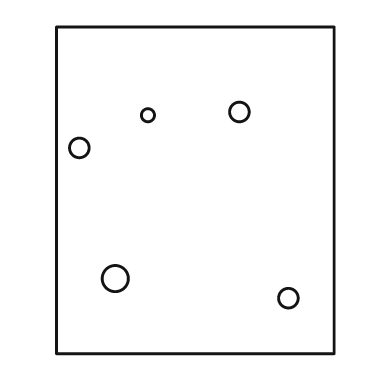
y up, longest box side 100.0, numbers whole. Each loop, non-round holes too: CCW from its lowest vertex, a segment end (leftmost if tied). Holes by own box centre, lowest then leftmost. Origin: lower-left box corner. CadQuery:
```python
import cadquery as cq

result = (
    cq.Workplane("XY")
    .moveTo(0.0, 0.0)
    .lineTo(85.0, 0.0)
    .lineTo(85.0, 100.0)
    .lineTo(0.0, 100.0)
    .close()
    .moveTo(71.0, 17.0)
    .circle(3.0)
    .moveTo(18.0, 23.0)
    .circle(4.0)
    .moveTo(7.0, 63.0)
    .circle(3.0)
    .moveTo(28.0, 73.0)
    .circle(2.0)
    .moveTo(56.0, 74.0)
    .circle(3.0)
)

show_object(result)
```